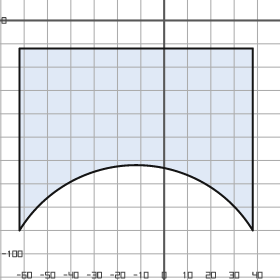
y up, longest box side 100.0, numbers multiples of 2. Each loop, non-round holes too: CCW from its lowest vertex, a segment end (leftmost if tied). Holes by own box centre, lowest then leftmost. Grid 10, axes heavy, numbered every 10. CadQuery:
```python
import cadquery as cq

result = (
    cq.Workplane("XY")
    .moveTo(-62.0, -90.0)
    .threePointArc((-12.0, -62.0), (38.0, -90.0))
    .lineTo(38.0, -12.0)
    .lineTo(-62.0, -12.0)
    .close()
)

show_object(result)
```